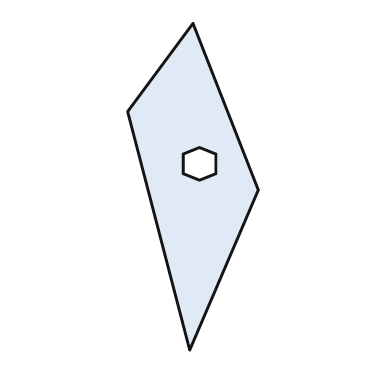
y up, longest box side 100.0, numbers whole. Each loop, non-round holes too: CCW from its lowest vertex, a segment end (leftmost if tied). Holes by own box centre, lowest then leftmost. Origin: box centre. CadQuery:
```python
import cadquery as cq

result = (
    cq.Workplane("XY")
    .moveTo(-1.0, -50.0)
    .lineTo(20.0, -1.0)
    .lineTo(0.0, 50.0)
    .lineTo(-20.0, 23.0)
    .close()
    .moveTo(2.0, 2.0)
    .lineTo(7.0, 4.0)
    .lineTo(7.0, 10.0)
    .lineTo(2.0, 12.0)
    .lineTo(-3.0, 10.0)
    .lineTo(-3.0, 4.0)
    .close()
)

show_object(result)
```